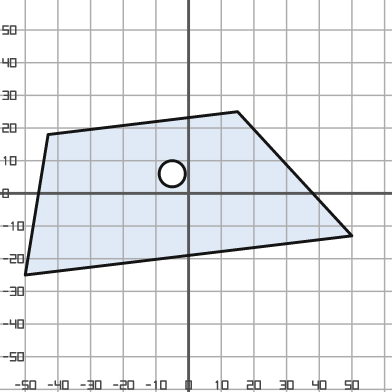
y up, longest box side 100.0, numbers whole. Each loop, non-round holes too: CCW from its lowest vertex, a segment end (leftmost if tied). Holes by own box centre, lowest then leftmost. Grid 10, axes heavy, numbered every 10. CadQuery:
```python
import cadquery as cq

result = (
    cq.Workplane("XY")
    .moveTo(-50.0, -25.0)
    .lineTo(50.0, -13.0)
    .lineTo(15.0, 25.0)
    .lineTo(-43.0, 18.0)
    .close()
    .moveTo(-5.0, 6.0)
    .circle(4.0)
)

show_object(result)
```